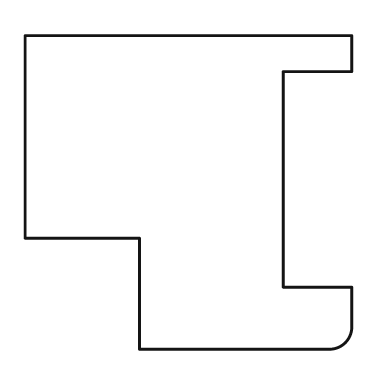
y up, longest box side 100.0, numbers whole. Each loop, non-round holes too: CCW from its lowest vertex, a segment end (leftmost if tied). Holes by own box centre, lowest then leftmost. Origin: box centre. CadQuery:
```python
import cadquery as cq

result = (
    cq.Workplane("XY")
    .moveTo(-15.0, -48.0)
    .lineTo(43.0, -48.0)
    .threePointArc((48.0, -46.0), (50.0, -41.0))
    .lineTo(50.0, -29.0)
    .lineTo(29.0, -29.0)
    .lineTo(29.0, 37.0)
    .lineTo(50.0, 37.0)
    .lineTo(50.0, 48.0)
    .lineTo(-50.0, 48.0)
    .lineTo(-50.0, -14.0)
    .lineTo(-15.0, -14.0)
    .close()
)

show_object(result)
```